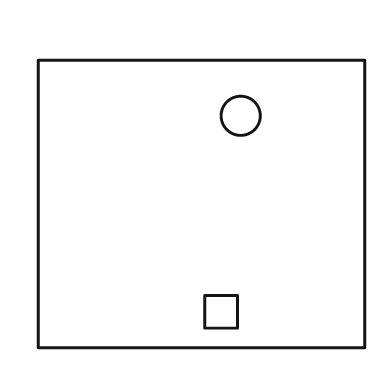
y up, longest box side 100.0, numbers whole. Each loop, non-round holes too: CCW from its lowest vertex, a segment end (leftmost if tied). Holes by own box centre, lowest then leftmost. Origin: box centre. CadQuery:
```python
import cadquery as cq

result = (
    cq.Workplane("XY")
    .moveTo(-50.0, -44.0)
    .lineTo(50.0, -44.0)
    .lineTo(50.0, 44.0)
    .lineTo(-50.0, 44.0)
    .close()
    .moveTo(1.0, -38.0)
    .lineTo(11.0, -38.0)
    .lineTo(11.0, -28.0)
    .lineTo(1.0, -28.0)
    .close()
    .moveTo(12.0, 27.0)
    .circle(6.0)
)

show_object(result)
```